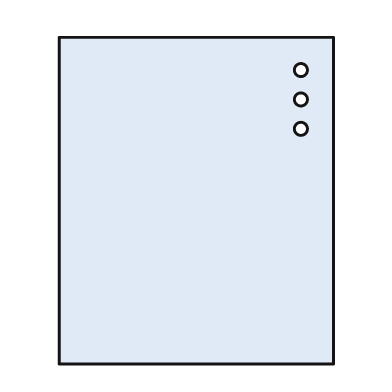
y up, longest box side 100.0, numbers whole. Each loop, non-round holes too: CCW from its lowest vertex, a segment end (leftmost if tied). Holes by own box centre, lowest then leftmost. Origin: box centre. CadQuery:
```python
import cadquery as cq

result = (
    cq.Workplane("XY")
    .moveTo(-42.0, -50.0)
    .lineTo(42.0, -50.0)
    .lineTo(42.0, 50.0)
    .lineTo(-42.0, 50.0)
    .close()
    .moveTo(32.0, 22.0)
    .circle(2.0)
    .moveTo(32.0, 31.0)
    .circle(2.0)
    .moveTo(32.0, 40.0)
    .circle(2.0)
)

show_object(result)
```